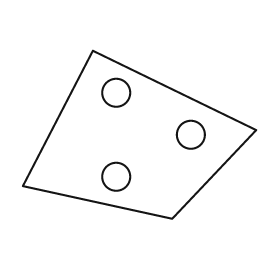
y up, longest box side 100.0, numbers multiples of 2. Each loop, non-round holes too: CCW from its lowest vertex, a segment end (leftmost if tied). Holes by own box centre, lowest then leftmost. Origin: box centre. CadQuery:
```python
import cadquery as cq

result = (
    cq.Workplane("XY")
    .moveTo(14.0, -36.0)
    .lineTo(50.0, 2.0)
    .lineTo(-20.0, 36.0)
    .lineTo(-50.0, -22.0)
    .close()
    .moveTo(-10.0, -18.0)
    .circle(6.0)
    .moveTo(22.0, 0.0)
    .circle(6.0)
    .moveTo(-10.0, 18.0)
    .circle(6.0)
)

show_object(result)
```